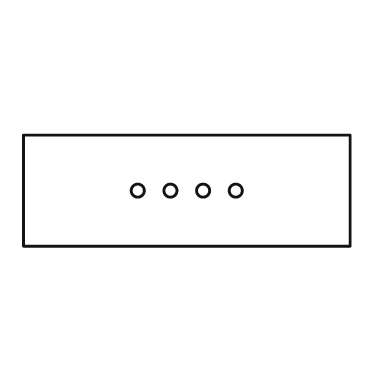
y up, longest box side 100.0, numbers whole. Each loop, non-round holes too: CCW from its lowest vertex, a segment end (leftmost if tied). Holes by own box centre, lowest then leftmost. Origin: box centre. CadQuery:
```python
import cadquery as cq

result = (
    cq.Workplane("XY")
    .moveTo(-50.0, -17.0)
    .lineTo(50.0, -17.0)
    .lineTo(50.0, 17.0)
    .lineTo(-50.0, 17.0)
    .close()
    .moveTo(-15.0, 0.0)
    .circle(2.0)
    .moveTo(-5.0, 0.0)
    .circle(2.0)
    .moveTo(5.0, 0.0)
    .circle(2.0)
    .moveTo(15.0, 0.0)
    .circle(2.0)
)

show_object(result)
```